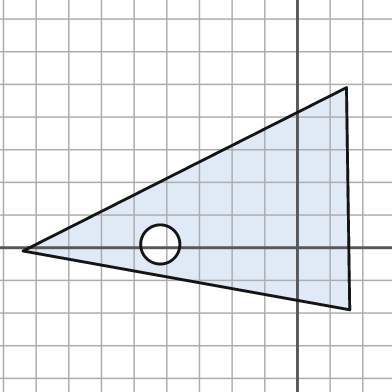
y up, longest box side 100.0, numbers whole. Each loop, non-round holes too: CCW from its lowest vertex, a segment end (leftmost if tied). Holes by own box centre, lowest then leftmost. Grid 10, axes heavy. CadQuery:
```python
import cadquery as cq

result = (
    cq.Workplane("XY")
    .moveTo(16.0, -19.0)
    .lineTo(15.0, 49.0)
    .lineTo(-84.0, -1.0)
    .close()
    .moveTo(-42.0, 1.0)
    .circle(6.0)
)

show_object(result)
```